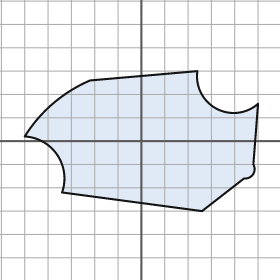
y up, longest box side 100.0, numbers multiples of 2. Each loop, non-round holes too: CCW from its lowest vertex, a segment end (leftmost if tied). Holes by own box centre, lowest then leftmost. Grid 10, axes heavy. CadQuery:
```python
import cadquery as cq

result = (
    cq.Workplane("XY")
    .moveTo(26.0, -30.0)
    .lineTo(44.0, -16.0)
    .threePointArc((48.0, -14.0), (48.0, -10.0))
    .lineTo(50.0, 16.0)
    .threePointArc((32.0, 14.0), (24.0, 30.0))
    .lineTo(-22.0, 26.0)
    .threePointArc((-38.0, 16.0), (-50.0, 2.0))
    .threePointArc((-36.0, -6.0), (-34.0, -22.0))
    .close()
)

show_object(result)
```